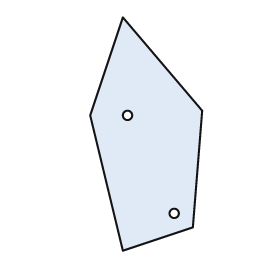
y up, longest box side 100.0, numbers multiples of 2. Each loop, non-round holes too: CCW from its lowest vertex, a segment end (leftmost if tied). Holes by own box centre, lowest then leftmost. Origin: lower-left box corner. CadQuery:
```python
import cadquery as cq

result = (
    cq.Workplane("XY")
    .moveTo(14.0, 0.0)
    .lineTo(44.0, 10.0)
    .lineTo(48.0, 60.0)
    .lineTo(14.0, 100.0)
    .lineTo(0.0, 58.0)
    .close()
    .moveTo(36.0, 16.0)
    .circle(2.0)
    .moveTo(16.0, 58.0)
    .circle(2.0)
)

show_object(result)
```